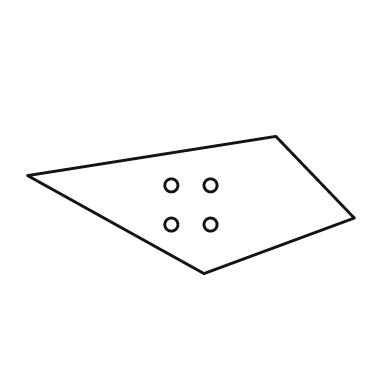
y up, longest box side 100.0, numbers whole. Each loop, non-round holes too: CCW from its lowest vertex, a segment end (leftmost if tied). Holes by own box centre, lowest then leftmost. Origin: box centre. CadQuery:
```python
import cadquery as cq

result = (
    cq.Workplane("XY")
    .moveTo(4.0, -21.0)
    .lineTo(50.0, -4.0)
    .lineTo(26.0, 21.0)
    .lineTo(-50.0, 9.0)
    .close()
    .moveTo(-6.0, -6.0)
    .circle(2.0)
    .moveTo(6.0, -6.0)
    .circle(2.0)
    .moveTo(-6.0, 6.0)
    .circle(2.0)
    .moveTo(6.0, 6.0)
    .circle(2.0)
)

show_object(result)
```